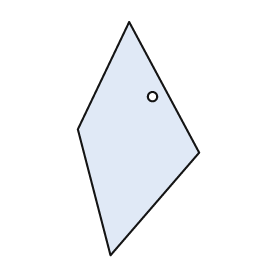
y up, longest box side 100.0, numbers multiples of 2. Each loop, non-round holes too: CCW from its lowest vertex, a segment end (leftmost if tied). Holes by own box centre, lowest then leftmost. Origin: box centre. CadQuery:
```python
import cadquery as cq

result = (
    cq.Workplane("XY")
    .moveTo(-12.0, -50.0)
    .lineTo(26.0, -6.0)
    .lineTo(-4.0, 50.0)
    .lineTo(-26.0, 4.0)
    .close()
    .moveTo(6.0, 18.0)
    .circle(2.0)
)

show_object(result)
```